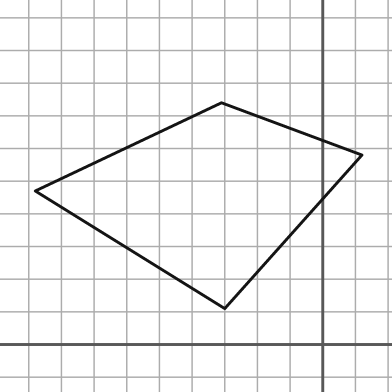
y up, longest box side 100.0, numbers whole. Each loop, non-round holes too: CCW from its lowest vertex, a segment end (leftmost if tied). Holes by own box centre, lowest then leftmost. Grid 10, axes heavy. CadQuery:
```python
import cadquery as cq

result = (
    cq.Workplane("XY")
    .moveTo(-30.0, 11.0)
    .lineTo(12.0, 58.0)
    .lineTo(-31.0, 74.0)
    .lineTo(-88.0, 47.0)
    .close()
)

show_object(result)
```